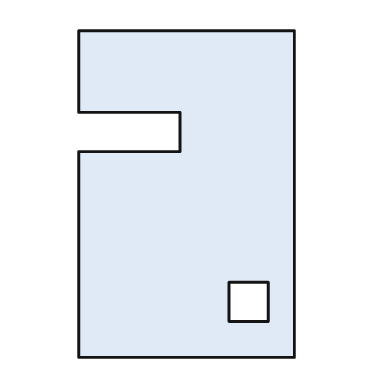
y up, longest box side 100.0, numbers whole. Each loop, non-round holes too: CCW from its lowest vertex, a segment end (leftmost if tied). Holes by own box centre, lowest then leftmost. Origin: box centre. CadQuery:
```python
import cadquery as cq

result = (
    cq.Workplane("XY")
    .moveTo(-33.0, -50.0)
    .lineTo(33.0, -50.0)
    .lineTo(33.0, 50.0)
    .lineTo(-33.0, 50.0)
    .lineTo(-33.0, 25.0)
    .lineTo(-2.0, 25.0)
    .lineTo(-2.0, 13.0)
    .lineTo(-33.0, 13.0)
    .close()
    .moveTo(13.0, -39.0)
    .lineTo(25.0, -39.0)
    .lineTo(25.0, -27.0)
    .lineTo(13.0, -27.0)
    .close()
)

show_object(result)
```